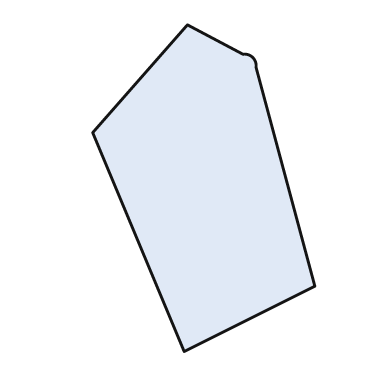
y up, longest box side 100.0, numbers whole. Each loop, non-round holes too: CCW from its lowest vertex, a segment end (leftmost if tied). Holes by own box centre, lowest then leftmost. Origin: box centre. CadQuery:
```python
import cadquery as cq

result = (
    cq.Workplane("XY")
    .moveTo(-6.0, -50.0)
    .lineTo(34.0, -30.0)
    .lineTo(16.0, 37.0)
    .threePointArc((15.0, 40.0), (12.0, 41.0))
    .lineTo(-5.0, 50.0)
    .lineTo(-34.0, 17.0)
    .close()
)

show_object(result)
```